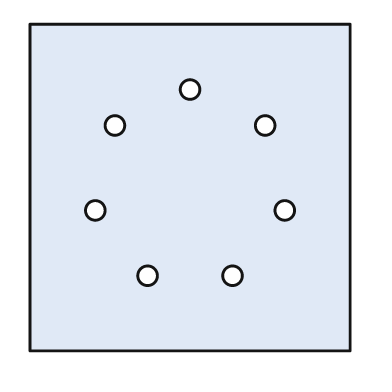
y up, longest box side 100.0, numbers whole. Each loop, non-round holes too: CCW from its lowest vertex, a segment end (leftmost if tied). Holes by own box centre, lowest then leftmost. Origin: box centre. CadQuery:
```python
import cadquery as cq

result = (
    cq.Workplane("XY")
    .moveTo(-49.0, -50.0)
    .lineTo(49.0, -50.0)
    .lineTo(49.0, 50.0)
    .lineTo(-49.0, 50.0)
    .close()
    .moveTo(-13.0, -27.0)
    .circle(3.0)
    .moveTo(13.0, -27.0)
    .circle(3.0)
    .moveTo(-29.0, -7.0)
    .circle(3.0)
    .moveTo(29.0, -7.0)
    .circle(3.0)
    .moveTo(-23.0, 19.0)
    .circle(3.0)
    .moveTo(23.0, 19.0)
    .circle(3.0)
    .moveTo(0.0, 30.0)
    .circle(3.0)
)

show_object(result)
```